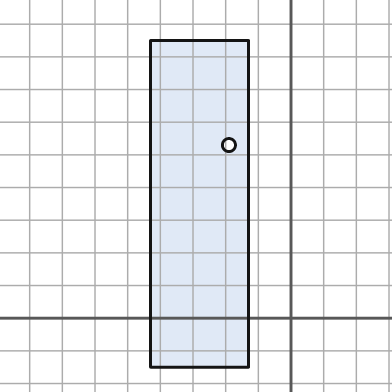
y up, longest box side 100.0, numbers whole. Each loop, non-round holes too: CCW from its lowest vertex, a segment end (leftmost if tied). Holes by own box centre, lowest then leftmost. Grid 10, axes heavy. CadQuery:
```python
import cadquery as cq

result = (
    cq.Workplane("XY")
    .moveTo(-43.0, -15.0)
    .lineTo(-13.0, -15.0)
    .lineTo(-13.0, 85.0)
    .lineTo(-43.0, 85.0)
    .close()
    .moveTo(-19.0, 53.0)
    .circle(2.0)
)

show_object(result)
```